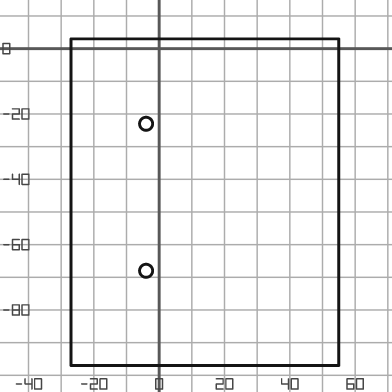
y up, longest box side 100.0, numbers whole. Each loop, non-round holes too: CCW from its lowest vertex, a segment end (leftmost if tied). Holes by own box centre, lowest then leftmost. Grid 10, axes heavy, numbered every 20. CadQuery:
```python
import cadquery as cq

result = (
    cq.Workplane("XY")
    .moveTo(-27.0, -97.0)
    .lineTo(55.0, -97.0)
    .lineTo(55.0, 3.0)
    .lineTo(-27.0, 3.0)
    .close()
    .moveTo(-4.0, -68.0)
    .circle(2.0)
    .moveTo(-4.0, -23.0)
    .circle(2.0)
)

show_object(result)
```